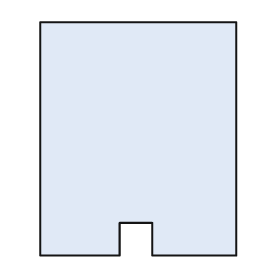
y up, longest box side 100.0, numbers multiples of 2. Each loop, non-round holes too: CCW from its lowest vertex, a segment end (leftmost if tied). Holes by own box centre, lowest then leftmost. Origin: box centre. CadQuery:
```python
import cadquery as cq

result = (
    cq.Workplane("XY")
    .moveTo(-42.0, -50.0)
    .lineTo(-8.0, -50.0)
    .lineTo(-8.0, -36.0)
    .lineTo(6.0, -36.0)
    .lineTo(6.0, -50.0)
    .lineTo(42.0, -50.0)
    .lineTo(42.0, 50.0)
    .lineTo(-42.0, 50.0)
    .close()
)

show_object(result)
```